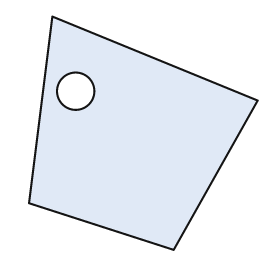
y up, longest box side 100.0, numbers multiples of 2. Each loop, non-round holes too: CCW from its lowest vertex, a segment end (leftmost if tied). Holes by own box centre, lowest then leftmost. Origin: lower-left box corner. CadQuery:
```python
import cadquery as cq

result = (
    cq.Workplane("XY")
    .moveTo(62.0, 0.0)
    .lineTo(98.0, 64.0)
    .lineTo(10.0, 100.0)
    .lineTo(0.0, 20.0)
    .close()
    .moveTo(20.0, 68.0)
    .circle(8.0)
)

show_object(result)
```